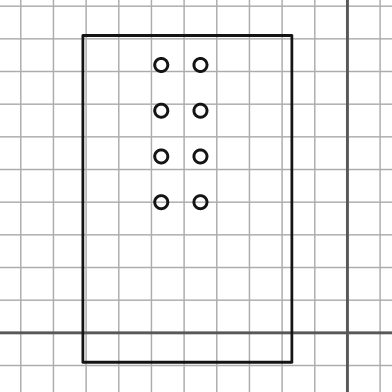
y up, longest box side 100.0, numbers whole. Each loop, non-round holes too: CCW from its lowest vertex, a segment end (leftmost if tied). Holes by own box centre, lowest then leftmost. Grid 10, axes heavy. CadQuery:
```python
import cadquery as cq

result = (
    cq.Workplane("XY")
    .moveTo(-81.0, -9.0)
    .lineTo(-17.0, -9.0)
    .lineTo(-17.0, 91.0)
    .lineTo(-81.0, 91.0)
    .close()
    .moveTo(-57.0, 40.0)
    .circle(2.0)
    .moveTo(-45.0, 40.0)
    .circle(2.0)
    .moveTo(-57.0, 54.0)
    .circle(2.0)
    .moveTo(-45.0, 54.0)
    .circle(2.0)
    .moveTo(-57.0, 68.0)
    .circle(2.0)
    .moveTo(-45.0, 68.0)
    .circle(2.0)
    .moveTo(-57.0, 82.0)
    .circle(2.0)
    .moveTo(-45.0, 82.0)
    .circle(2.0)
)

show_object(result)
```